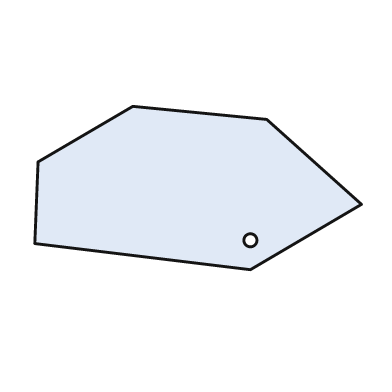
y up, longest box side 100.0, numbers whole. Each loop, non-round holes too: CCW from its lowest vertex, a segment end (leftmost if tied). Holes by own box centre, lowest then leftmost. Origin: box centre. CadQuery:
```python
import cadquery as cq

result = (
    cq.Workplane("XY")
    .moveTo(16.0, -25.0)
    .lineTo(50.0, -5.0)
    .lineTo(21.0, 21.0)
    .lineTo(-20.0, 25.0)
    .lineTo(-49.0, 8.0)
    .lineTo(-50.0, -17.0)
    .close()
    .moveTo(16.0, -16.0)
    .circle(2.0)
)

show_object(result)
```